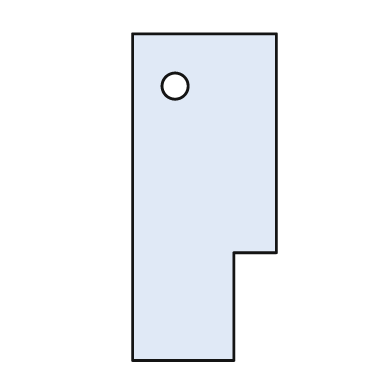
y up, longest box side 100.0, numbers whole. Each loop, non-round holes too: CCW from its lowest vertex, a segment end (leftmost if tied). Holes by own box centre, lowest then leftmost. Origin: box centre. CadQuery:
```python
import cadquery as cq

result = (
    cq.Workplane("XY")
    .moveTo(-22.0, -50.0)
    .lineTo(9.0, -50.0)
    .lineTo(9.0, -17.0)
    .lineTo(22.0, -17.0)
    .lineTo(22.0, 50.0)
    .lineTo(-22.0, 50.0)
    .close()
    .moveTo(-9.0, 34.0)
    .circle(4.0)
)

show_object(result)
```